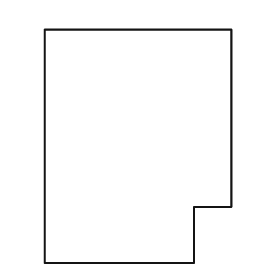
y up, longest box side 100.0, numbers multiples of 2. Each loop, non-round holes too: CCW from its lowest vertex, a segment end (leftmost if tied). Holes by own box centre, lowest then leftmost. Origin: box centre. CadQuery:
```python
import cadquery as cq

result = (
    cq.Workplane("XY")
    .moveTo(-40.0, -50.0)
    .lineTo(24.0, -50.0)
    .lineTo(24.0, -26.0)
    .lineTo(40.0, -26.0)
    .lineTo(40.0, 50.0)
    .lineTo(-40.0, 50.0)
    .close()
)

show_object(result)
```